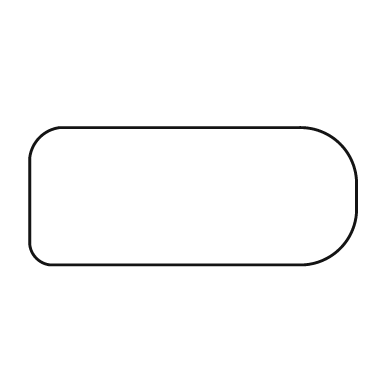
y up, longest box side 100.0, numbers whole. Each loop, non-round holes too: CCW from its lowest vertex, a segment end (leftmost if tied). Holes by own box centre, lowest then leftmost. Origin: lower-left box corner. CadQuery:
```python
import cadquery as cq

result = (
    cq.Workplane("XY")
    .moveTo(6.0, 0.0)
    .lineTo(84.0, 0.0)
    .threePointArc((95.0, 5.0), (100.0, 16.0))
    .lineTo(100.0, 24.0)
    .threePointArc((95.0, 37.0), (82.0, 42.0))
    .lineTo(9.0, 42.0)
    .threePointArc((3.0, 39.0), (0.0, 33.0))
    .lineTo(0.0, 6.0)
    .threePointArc((2.0, 2.0), (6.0, 0.0))
    .close()
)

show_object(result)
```